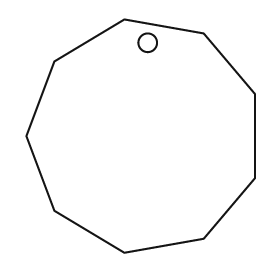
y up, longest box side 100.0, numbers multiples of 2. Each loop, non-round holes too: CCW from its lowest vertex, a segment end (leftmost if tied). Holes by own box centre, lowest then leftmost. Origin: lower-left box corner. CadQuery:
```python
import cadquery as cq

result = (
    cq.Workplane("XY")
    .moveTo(42.0, 0.0)
    .lineTo(76.0, 6.0)
    .lineTo(98.0, 32.0)
    .lineTo(98.0, 68.0)
    .lineTo(76.0, 94.0)
    .lineTo(42.0, 100.0)
    .lineTo(12.0, 82.0)
    .lineTo(0.0, 50.0)
    .lineTo(12.0, 18.0)
    .close()
    .moveTo(52.0, 90.0)
    .circle(4.0)
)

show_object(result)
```